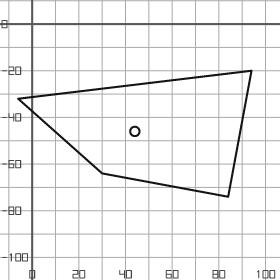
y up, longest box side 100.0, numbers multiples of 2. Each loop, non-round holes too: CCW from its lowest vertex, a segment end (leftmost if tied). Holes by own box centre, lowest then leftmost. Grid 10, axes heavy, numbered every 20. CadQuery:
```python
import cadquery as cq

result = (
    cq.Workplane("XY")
    .moveTo(84.0, -74.0)
    .lineTo(94.0, -20.0)
    .lineTo(-6.0, -32.0)
    .lineTo(30.0, -64.0)
    .close()
    .moveTo(44.0, -46.0)
    .circle(2.0)
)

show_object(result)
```